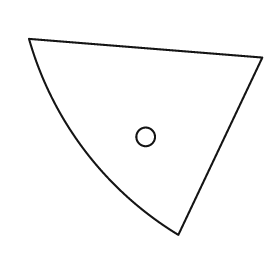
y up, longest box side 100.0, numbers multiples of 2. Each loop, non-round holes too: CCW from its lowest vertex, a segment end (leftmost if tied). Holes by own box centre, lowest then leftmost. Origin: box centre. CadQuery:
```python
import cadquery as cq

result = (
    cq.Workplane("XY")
    .moveTo(14.0, -42.0)
    .lineTo(50.0, 34.0)
    .lineTo(-50.0, 42.0)
    .threePointArc((-26.0, -6.0), (14.0, -42.0))
    .close()
    .moveTo(0.0, 0.0)
    .circle(4.0)
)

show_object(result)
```